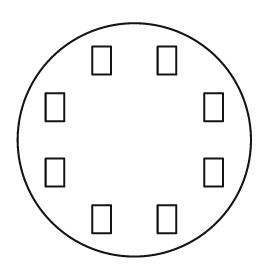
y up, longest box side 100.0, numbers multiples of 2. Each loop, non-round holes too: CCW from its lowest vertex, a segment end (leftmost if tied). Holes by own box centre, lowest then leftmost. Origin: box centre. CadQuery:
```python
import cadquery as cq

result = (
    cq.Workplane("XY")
    .moveTo(0.0, 0.0)
    .circle(50.0)
    .moveTo(-18.0, -40.0)
    .lineTo(-10.0, -40.0)
    .lineTo(-10.0, -28.0)
    .lineTo(-18.0, -28.0)
    .close()
    .moveTo(10.0, -40.0)
    .lineTo(18.0, -40.0)
    .lineTo(18.0, -28.0)
    .lineTo(10.0, -28.0)
    .close()
    .moveTo(-38.0, -20.0)
    .lineTo(-30.0, -20.0)
    .lineTo(-30.0, -8.0)
    .lineTo(-38.0, -8.0)
    .close()
    .moveTo(30.0, -20.0)
    .lineTo(38.0, -20.0)
    .lineTo(38.0, -8.0)
    .lineTo(30.0, -8.0)
    .close()
    .moveTo(-38.0, 8.0)
    .lineTo(-30.0, 8.0)
    .lineTo(-30.0, 20.0)
    .lineTo(-38.0, 20.0)
    .close()
    .moveTo(30.0, 8.0)
    .lineTo(38.0, 8.0)
    .lineTo(38.0, 20.0)
    .lineTo(30.0, 20.0)
    .close()
    .moveTo(-18.0, 28.0)
    .lineTo(-10.0, 28.0)
    .lineTo(-10.0, 40.0)
    .lineTo(-18.0, 40.0)
    .close()
    .moveTo(10.0, 28.0)
    .lineTo(18.0, 28.0)
    .lineTo(18.0, 40.0)
    .lineTo(10.0, 40.0)
    .close()
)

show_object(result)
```